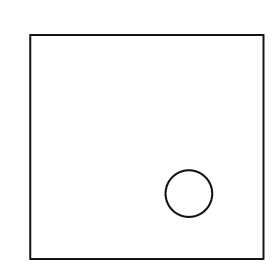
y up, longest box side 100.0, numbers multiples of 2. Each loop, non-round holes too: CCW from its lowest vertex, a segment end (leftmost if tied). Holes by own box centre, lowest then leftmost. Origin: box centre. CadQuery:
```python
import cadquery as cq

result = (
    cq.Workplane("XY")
    .moveTo(-50.0, -48.0)
    .lineTo(50.0, -48.0)
    .lineTo(50.0, 48.0)
    .lineTo(-50.0, 48.0)
    .close()
    .moveTo(18.0, -20.0)
    .circle(10.0)
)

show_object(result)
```